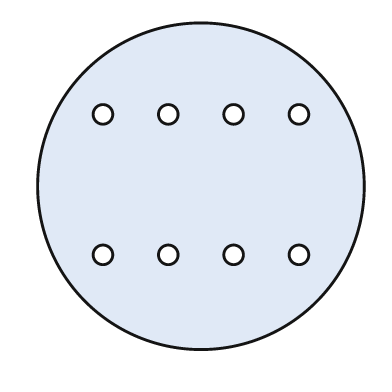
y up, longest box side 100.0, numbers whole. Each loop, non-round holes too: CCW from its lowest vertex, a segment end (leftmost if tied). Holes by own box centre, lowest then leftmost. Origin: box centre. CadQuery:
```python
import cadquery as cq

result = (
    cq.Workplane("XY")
    .moveTo(0.0, 0.0)
    .circle(50.0)
    .moveTo(-30.0, -21.0)
    .circle(3.0)
    .moveTo(-10.0, -21.0)
    .circle(3.0)
    .moveTo(10.0, -21.0)
    .circle(3.0)
    .moveTo(30.0, -21.0)
    .circle(3.0)
    .moveTo(-30.0, 22.0)
    .circle(3.0)
    .moveTo(-10.0, 22.0)
    .circle(3.0)
    .moveTo(10.0, 22.0)
    .circle(3.0)
    .moveTo(30.0, 22.0)
    .circle(3.0)
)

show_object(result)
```